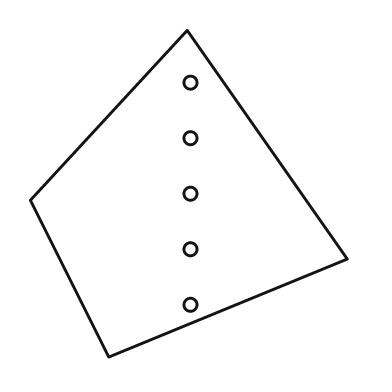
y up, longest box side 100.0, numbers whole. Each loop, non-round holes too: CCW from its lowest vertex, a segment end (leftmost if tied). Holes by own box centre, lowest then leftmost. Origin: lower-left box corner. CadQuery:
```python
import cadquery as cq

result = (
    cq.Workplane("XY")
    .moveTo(24.0, 0.0)
    .lineTo(97.0, 30.0)
    .lineTo(48.0, 100.0)
    .lineTo(0.0, 48.0)
    .close()
    .moveTo(49.0, 16.0)
    .circle(2.0)
    .moveTo(49.0, 33.0)
    .circle(2.0)
    .moveTo(49.0, 50.0)
    .circle(2.0)
    .moveTo(49.0, 67.0)
    .circle(2.0)
    .moveTo(49.0, 84.0)
    .circle(2.0)
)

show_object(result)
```